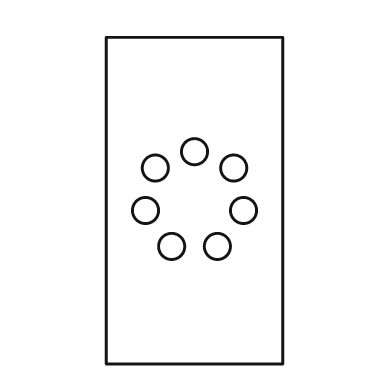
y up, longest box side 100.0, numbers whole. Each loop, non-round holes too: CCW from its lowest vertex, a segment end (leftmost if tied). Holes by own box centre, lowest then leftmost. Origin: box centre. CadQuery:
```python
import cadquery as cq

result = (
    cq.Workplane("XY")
    .moveTo(-27.0, -50.0)
    .lineTo(27.0, -50.0)
    .lineTo(27.0, 50.0)
    .lineTo(-27.0, 50.0)
    .close()
    .moveTo(-7.0, -14.0)
    .circle(4.0)
    .moveTo(7.0, -14.0)
    .circle(4.0)
    .moveTo(-15.0, -3.0)
    .circle(4.0)
    .moveTo(15.0, -3.0)
    .circle(4.0)
    .moveTo(-12.0, 10.0)
    .circle(4.0)
    .moveTo(12.0, 10.0)
    .circle(4.0)
    .moveTo(0.0, 15.0)
    .circle(4.0)
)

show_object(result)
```